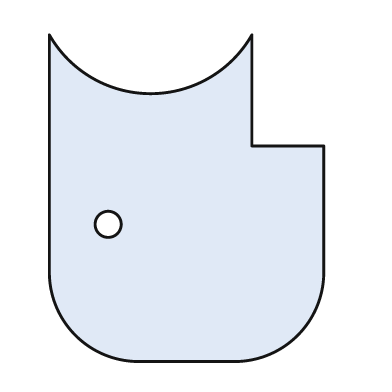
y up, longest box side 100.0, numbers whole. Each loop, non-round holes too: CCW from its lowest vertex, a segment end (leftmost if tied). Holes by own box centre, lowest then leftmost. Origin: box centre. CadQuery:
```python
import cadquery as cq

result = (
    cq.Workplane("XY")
    .moveTo(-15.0, -50.0)
    .lineTo(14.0, -50.0)
    .threePointArc((34.0, -42.0), (42.0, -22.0))
    .lineTo(42.0, 16.0)
    .lineTo(20.0, 16.0)
    .lineTo(20.0, 50.0)
    .threePointArc((-11.0, 32.0), (-42.0, 50.0))
    .lineTo(-42.0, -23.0)
    .threePointArc((-34.0, -42.0), (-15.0, -50.0))
    .close()
    .moveTo(-24.0, -8.0)
    .circle(4.0)
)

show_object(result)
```